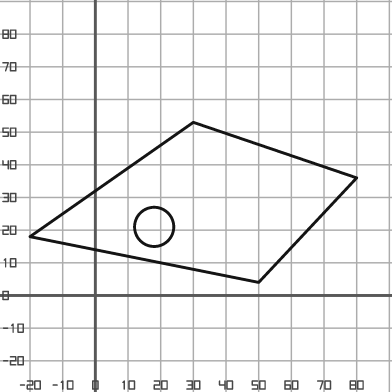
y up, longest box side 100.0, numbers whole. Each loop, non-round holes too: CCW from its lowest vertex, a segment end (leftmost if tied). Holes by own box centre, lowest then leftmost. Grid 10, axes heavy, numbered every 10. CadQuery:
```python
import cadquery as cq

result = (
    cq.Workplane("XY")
    .moveTo(50.0, 4.0)
    .lineTo(80.0, 36.0)
    .lineTo(30.0, 53.0)
    .lineTo(-20.0, 18.0)
    .close()
    .moveTo(18.0, 21.0)
    .circle(6.0)
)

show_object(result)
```